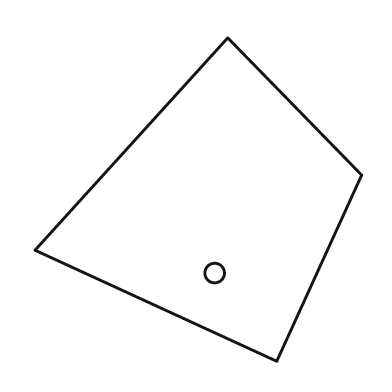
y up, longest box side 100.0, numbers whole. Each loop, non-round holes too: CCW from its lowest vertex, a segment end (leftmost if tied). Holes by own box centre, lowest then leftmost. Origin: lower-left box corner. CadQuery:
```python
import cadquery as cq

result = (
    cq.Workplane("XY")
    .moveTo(74.0, 0.0)
    .lineTo(100.0, 57.0)
    .lineTo(59.0, 99.0)
    .lineTo(0.0, 34.0)
    .close()
    .moveTo(55.0, 27.0)
    .circle(3.0)
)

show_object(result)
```